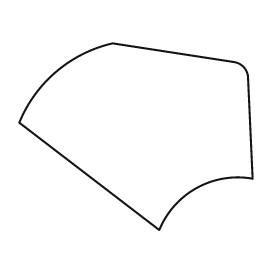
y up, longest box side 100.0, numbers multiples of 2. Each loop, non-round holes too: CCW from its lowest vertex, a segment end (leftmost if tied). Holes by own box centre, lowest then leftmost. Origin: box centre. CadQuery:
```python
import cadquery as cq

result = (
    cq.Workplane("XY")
    .moveTo(10.0, -40.0)
    .threePointArc((26.0, -22.0), (50.0, -18.0))
    .lineTo(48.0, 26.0)
    .threePointArc((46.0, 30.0), (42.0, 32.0))
    .lineTo(-10.0, 40.0)
    .threePointArc((-34.0, 28.0), (-50.0, 6.0))
    .close()
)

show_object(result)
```